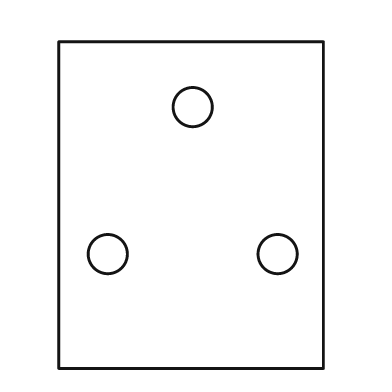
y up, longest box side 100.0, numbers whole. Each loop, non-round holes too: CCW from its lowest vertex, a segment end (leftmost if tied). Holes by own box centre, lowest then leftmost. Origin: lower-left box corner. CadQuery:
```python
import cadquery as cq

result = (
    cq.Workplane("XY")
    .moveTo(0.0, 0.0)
    .lineTo(81.0, 0.0)
    .lineTo(81.0, 100.0)
    .lineTo(0.0, 100.0)
    .close()
    .moveTo(15.0, 35.0)
    .circle(6.0)
    .moveTo(67.0, 35.0)
    .circle(6.0)
    .moveTo(41.0, 80.0)
    .circle(6.0)
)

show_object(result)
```